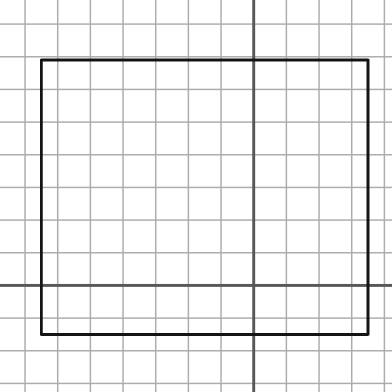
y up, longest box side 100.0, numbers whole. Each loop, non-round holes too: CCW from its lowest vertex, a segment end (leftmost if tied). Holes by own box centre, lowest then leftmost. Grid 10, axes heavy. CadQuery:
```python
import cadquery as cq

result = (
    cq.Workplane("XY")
    .moveTo(-65.0, -15.0)
    .lineTo(35.0, -15.0)
    .lineTo(35.0, 69.0)
    .lineTo(-65.0, 69.0)
    .close()
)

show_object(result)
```